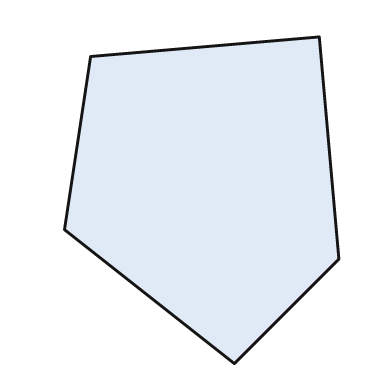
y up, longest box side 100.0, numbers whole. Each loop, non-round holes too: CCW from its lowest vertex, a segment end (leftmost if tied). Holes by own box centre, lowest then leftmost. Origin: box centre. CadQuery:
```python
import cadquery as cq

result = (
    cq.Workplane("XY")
    .moveTo(10.0, -50.0)
    .lineTo(42.0, -18.0)
    .lineTo(36.0, 50.0)
    .lineTo(-34.0, 44.0)
    .lineTo(-42.0, -9.0)
    .close()
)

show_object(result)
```